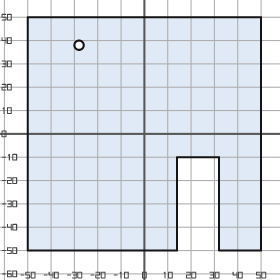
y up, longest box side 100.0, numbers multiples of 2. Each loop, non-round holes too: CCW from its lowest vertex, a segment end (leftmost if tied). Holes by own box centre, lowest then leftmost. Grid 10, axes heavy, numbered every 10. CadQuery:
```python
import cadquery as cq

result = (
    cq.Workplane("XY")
    .moveTo(-50.0, -50.0)
    .lineTo(14.0, -50.0)
    .lineTo(14.0, -10.0)
    .lineTo(32.0, -10.0)
    .lineTo(32.0, -50.0)
    .lineTo(50.0, -50.0)
    .lineTo(50.0, 50.0)
    .lineTo(-50.0, 50.0)
    .close()
    .moveTo(-28.0, 38.0)
    .circle(2.0)
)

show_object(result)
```